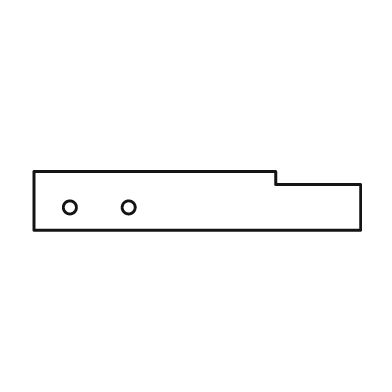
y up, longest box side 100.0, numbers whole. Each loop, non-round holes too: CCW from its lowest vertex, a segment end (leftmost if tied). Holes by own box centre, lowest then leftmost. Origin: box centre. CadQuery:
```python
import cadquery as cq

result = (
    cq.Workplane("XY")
    .moveTo(-50.0, -9.0)
    .lineTo(50.0, -9.0)
    .lineTo(50.0, 5.0)
    .lineTo(24.0, 5.0)
    .lineTo(24.0, 9.0)
    .lineTo(-50.0, 9.0)
    .close()
    .moveTo(-39.0, -2.0)
    .circle(2.0)
    .moveTo(-21.0, -2.0)
    .circle(2.0)
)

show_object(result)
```